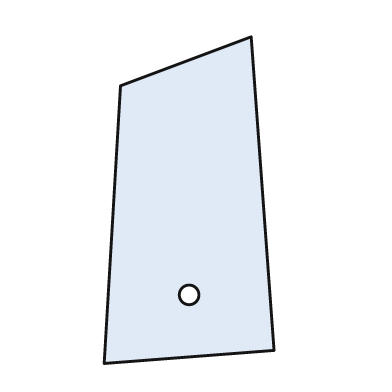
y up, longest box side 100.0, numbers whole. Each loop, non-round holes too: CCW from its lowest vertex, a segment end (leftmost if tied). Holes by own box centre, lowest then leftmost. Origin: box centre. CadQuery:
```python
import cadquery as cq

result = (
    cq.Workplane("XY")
    .moveTo(-26.0, -50.0)
    .lineTo(26.0, -46.0)
    .lineTo(19.0, 50.0)
    .lineTo(-21.0, 35.0)
    .close()
    .moveTo(0.0, -29.0)
    .circle(3.0)
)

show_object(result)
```